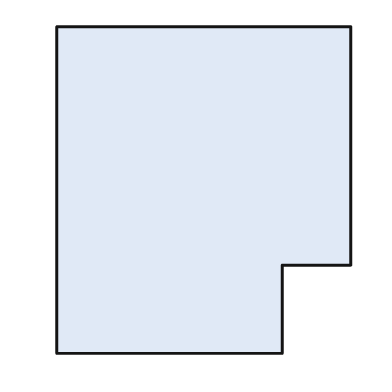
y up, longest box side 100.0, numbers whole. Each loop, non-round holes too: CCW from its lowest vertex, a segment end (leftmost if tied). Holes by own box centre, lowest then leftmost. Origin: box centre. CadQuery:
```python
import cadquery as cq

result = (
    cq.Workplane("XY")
    .moveTo(-45.0, -50.0)
    .lineTo(24.0, -50.0)
    .lineTo(24.0, -23.0)
    .lineTo(45.0, -23.0)
    .lineTo(45.0, 50.0)
    .lineTo(-45.0, 50.0)
    .close()
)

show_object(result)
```